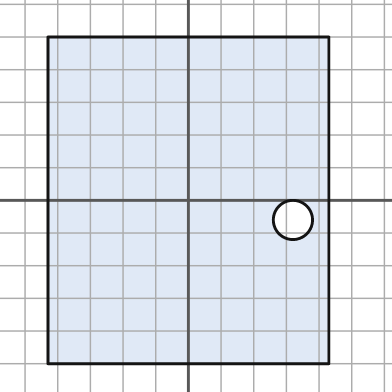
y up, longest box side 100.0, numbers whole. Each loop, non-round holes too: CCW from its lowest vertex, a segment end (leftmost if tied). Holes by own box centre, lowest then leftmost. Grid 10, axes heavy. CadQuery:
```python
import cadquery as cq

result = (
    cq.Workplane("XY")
    .moveTo(-43.0, -50.0)
    .lineTo(43.0, -50.0)
    .lineTo(43.0, 50.0)
    .lineTo(-43.0, 50.0)
    .close()
    .moveTo(32.0, -6.0)
    .circle(6.0)
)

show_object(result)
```